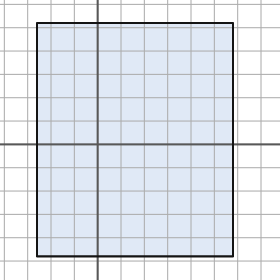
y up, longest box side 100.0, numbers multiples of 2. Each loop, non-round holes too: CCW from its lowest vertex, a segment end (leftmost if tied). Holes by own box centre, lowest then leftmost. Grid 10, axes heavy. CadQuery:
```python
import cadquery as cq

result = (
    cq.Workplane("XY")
    .moveTo(-26.0, -48.0)
    .lineTo(58.0, -48.0)
    .lineTo(58.0, 52.0)
    .lineTo(-26.0, 52.0)
    .close()
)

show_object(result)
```